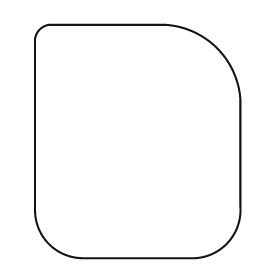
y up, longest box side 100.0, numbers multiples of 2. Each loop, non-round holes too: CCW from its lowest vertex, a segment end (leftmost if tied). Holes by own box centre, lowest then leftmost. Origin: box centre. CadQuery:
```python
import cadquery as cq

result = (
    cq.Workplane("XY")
    .moveTo(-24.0, -50.0)
    .lineTo(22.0, -50.0)
    .threePointArc((38.0, -44.0), (44.0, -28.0))
    .lineTo(44.0, 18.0)
    .threePointArc((34.0, 40.0), (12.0, 50.0))
    .lineTo(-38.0, 50.0)
    .threePointArc((-42.0, 48.0), (-44.0, 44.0))
    .lineTo(-44.0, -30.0)
    .threePointArc((-38.0, -44.0), (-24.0, -50.0))
    .close()
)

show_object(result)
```